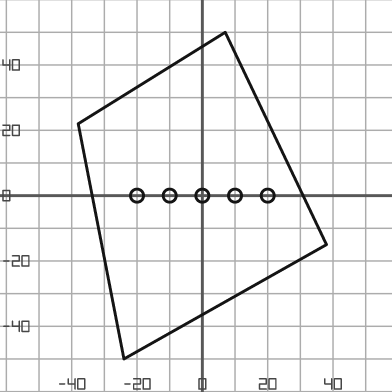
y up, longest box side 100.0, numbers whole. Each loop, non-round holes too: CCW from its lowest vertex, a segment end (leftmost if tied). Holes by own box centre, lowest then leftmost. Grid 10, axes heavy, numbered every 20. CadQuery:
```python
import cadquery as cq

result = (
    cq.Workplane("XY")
    .moveTo(-24.0, -50.0)
    .lineTo(38.0, -15.0)
    .lineTo(7.0, 50.0)
    .lineTo(-38.0, 22.0)
    .close()
    .moveTo(-20.0, 0.0)
    .circle(2.0)
    .moveTo(-10.0, 0.0)
    .circle(2.0)
    .moveTo(0.0, 0.0)
    .circle(2.0)
    .moveTo(10.0, 0.0)
    .circle(2.0)
    .moveTo(20.0, 0.0)
    .circle(2.0)
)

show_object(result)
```